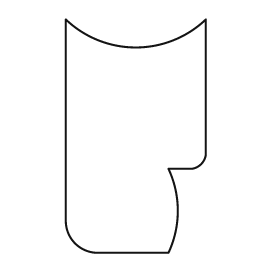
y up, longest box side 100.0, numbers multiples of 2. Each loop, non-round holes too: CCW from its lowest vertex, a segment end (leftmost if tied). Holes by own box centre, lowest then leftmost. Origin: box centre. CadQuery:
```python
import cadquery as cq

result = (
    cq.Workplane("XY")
    .moveTo(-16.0, -50.0)
    .lineTo(14.0, -50.0)
    .threePointArc((18.0, -32.0), (14.0, -14.0))
    .lineTo(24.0, -14.0)
    .threePointArc((28.0, -12.0), (30.0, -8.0))
    .lineTo(30.0, 50.0)
    .threePointArc((0.0, 38.0), (-30.0, 50.0))
    .lineTo(-30.0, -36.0)
    .threePointArc((-26.0, -46.0), (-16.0, -50.0))
    .close()
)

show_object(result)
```